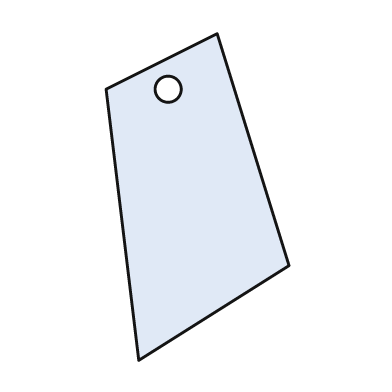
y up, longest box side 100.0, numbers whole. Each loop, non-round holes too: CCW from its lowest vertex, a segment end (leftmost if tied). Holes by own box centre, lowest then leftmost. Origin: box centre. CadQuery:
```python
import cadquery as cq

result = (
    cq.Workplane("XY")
    .moveTo(-18.0, -50.0)
    .lineTo(28.0, -21.0)
    .lineTo(6.0, 50.0)
    .lineTo(-28.0, 33.0)
    .close()
    .moveTo(-9.0, 33.0)
    .circle(4.0)
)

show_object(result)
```